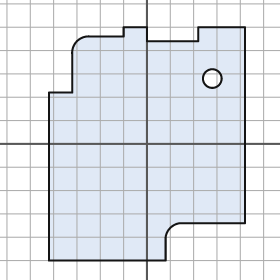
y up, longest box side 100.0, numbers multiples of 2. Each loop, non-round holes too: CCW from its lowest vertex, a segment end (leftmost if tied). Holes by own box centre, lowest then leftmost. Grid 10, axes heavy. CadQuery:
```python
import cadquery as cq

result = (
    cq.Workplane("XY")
    .moveTo(-42.0, -50.0)
    .lineTo(8.0, -50.0)
    .lineTo(8.0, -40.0)
    .threePointArc((10.0, -36.0), (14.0, -34.0))
    .lineTo(42.0, -34.0)
    .lineTo(42.0, 50.0)
    .lineTo(22.0, 50.0)
    .lineTo(22.0, 44.0)
    .lineTo(0.0, 44.0)
    .lineTo(0.0, 50.0)
    .lineTo(-10.0, 50.0)
    .lineTo(-10.0, 46.0)
    .lineTo(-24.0, 46.0)
    .threePointArc((-30.0, 44.0), (-32.0, 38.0))
    .lineTo(-32.0, 22.0)
    .lineTo(-42.0, 22.0)
    .close()
    .moveTo(28.0, 28.0)
    .circle(4.0)
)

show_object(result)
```